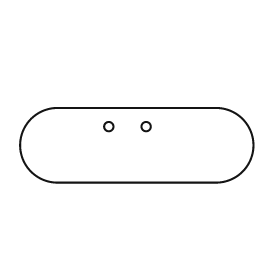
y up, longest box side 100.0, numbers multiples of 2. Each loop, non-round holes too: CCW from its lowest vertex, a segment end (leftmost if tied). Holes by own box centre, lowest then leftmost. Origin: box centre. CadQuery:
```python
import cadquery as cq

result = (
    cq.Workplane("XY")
    .moveTo(-34.0, -16.0)
    .lineTo(34.0, -16.0)
    .threePointArc((50.0, 0.0), (34.0, 16.0))
    .lineTo(-34.0, 16.0)
    .threePointArc((-50.0, 0.0), (-34.0, -16.0))
    .close()
    .moveTo(-12.0, 8.0)
    .circle(2.0)
    .moveTo(4.0, 8.0)
    .circle(2.0)
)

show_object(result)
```